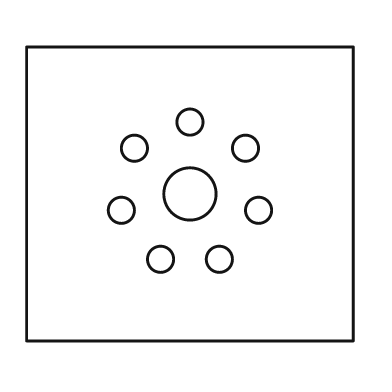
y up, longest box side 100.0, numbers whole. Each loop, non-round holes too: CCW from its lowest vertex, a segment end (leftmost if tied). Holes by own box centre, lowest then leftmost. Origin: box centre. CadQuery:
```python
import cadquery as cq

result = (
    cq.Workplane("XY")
    .moveTo(-50.0, -45.0)
    .lineTo(50.0, -45.0)
    .lineTo(50.0, 45.0)
    .lineTo(-50.0, 45.0)
    .close()
    .moveTo(-9.0, -20.0)
    .circle(4.0)
    .moveTo(9.0, -20.0)
    .circle(4.0)
    .moveTo(-21.0, -5.0)
    .circle(4.0)
    .moveTo(21.0, -5.0)
    .circle(4.0)
    .moveTo(0.0, 0.0)
    .circle(8.0)
    .moveTo(-17.0, 14.0)
    .circle(4.0)
    .moveTo(17.0, 14.0)
    .circle(4.0)
    .moveTo(0.0, 22.0)
    .circle(4.0)
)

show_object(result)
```